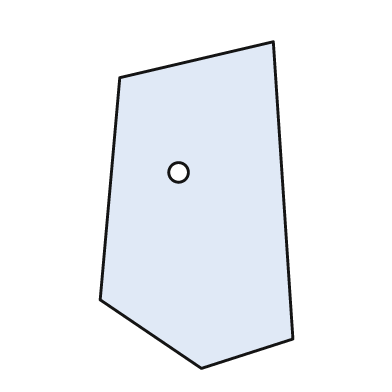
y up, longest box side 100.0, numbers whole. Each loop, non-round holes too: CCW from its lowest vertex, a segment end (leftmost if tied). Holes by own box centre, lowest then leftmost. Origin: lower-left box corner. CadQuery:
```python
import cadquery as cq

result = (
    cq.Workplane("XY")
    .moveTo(31.0, 0.0)
    .lineTo(59.0, 9.0)
    .lineTo(53.0, 100.0)
    .lineTo(6.0, 89.0)
    .lineTo(0.0, 21.0)
    .close()
    .moveTo(24.0, 60.0)
    .circle(3.0)
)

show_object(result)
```